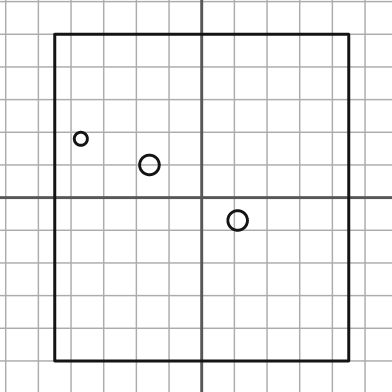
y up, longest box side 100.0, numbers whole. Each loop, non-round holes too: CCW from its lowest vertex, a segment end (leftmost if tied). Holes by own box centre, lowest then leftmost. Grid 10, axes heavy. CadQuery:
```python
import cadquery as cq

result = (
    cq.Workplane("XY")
    .moveTo(-45.0, -50.0)
    .lineTo(45.0, -50.0)
    .lineTo(45.0, 50.0)
    .lineTo(-45.0, 50.0)
    .close()
    .moveTo(11.0, -7.0)
    .circle(3.0)
    .moveTo(-16.0, 10.0)
    .circle(3.0)
    .moveTo(-37.0, 18.0)
    .circle(2.0)
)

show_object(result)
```